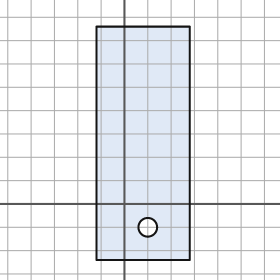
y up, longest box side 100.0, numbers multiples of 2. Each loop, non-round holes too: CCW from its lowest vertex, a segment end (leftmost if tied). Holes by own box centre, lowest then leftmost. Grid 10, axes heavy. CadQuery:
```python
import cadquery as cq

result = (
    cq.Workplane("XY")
    .moveTo(-12.0, -24.0)
    .lineTo(28.0, -24.0)
    .lineTo(28.0, 76.0)
    .lineTo(-12.0, 76.0)
    .close()
    .moveTo(10.0, -10.0)
    .circle(4.0)
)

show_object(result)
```